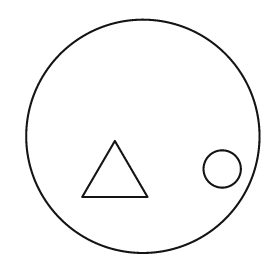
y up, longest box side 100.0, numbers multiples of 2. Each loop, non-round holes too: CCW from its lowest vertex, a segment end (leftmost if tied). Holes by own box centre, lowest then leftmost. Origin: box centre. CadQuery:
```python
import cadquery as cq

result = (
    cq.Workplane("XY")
    .moveTo(0.0, 0.0)
    .circle(50.0)
    .moveTo(-26.0, -26.0)
    .lineTo(2.0, -26.0)
    .lineTo(-12.0, -2.0)
    .close()
    .moveTo(34.0, -14.0)
    .circle(8.0)
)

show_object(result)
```